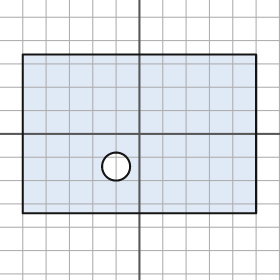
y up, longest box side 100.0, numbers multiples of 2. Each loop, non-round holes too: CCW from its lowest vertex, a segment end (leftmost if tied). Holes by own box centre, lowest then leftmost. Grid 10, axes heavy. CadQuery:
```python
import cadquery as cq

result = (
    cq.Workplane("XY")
    .moveTo(-50.0, -34.0)
    .lineTo(50.0, -34.0)
    .lineTo(50.0, 34.0)
    .lineTo(-50.0, 34.0)
    .close()
    .moveTo(-10.0, -14.0)
    .circle(6.0)
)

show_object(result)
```